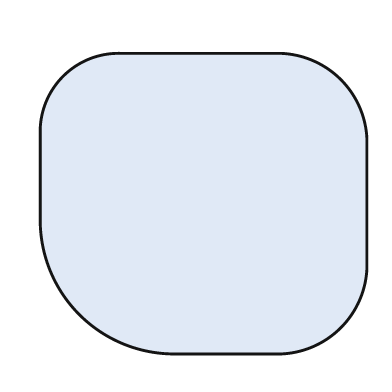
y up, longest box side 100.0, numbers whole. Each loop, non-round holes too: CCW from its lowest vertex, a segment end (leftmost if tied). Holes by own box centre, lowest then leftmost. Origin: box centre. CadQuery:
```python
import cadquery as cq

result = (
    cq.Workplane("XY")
    .moveTo(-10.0, -46.0)
    .lineTo(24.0, -46.0)
    .threePointArc((42.0, -38.0), (50.0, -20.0))
    .lineTo(50.0, 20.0)
    .threePointArc((42.0, 38.0), (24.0, 46.0))
    .lineTo(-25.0, 46.0)
    .threePointArc((-43.0, 39.0), (-50.0, 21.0))
    .lineTo(-50.0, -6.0)
    .threePointArc((-38.0, -34.0), (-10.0, -46.0))
    .close()
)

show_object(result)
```